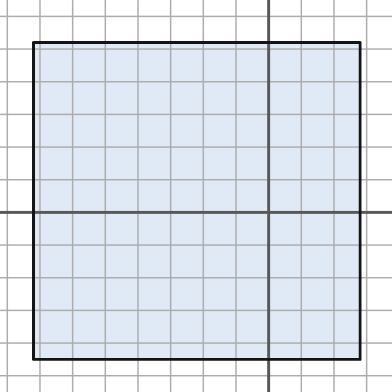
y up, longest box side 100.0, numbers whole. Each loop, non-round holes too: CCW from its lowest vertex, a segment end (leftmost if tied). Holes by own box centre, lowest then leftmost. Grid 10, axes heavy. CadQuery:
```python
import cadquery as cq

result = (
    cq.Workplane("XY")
    .moveTo(-72.0, -45.0)
    .lineTo(28.0, -45.0)
    .lineTo(28.0, 52.0)
    .lineTo(-72.0, 52.0)
    .close()
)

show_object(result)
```